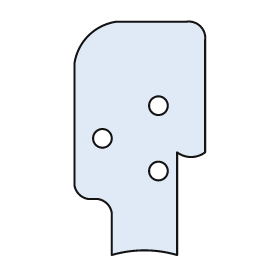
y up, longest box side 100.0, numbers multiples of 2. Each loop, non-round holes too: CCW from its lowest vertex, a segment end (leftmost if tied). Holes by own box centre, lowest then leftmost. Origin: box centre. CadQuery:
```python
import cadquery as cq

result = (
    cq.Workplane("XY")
    .moveTo(-12.0, -50.0)
    .threePointArc((2.0, -48.0), (16.0, -50.0))
    .lineTo(16.0, -6.0)
    .threePointArc((22.0, -8.0), (28.0, -6.0))
    .lineTo(28.0, 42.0)
    .threePointArc((26.0, 48.0), (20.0, 50.0))
    .lineTo(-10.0, 50.0)
    .threePointArc((-22.0, 44.0), (-28.0, 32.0))
    .lineTo(-28.0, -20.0)
    .threePointArc((-26.0, -24.0), (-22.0, -26.0))
    .lineTo(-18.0, -26.0)
    .threePointArc((-14.0, -28.0), (-12.0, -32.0))
    .close()
    .moveTo(8.0, -14.0)
    .circle(4.0)
    .moveTo(-16.0, 0.0)
    .circle(4.0)
    .moveTo(8.0, 14.0)
    .circle(4.0)
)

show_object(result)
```